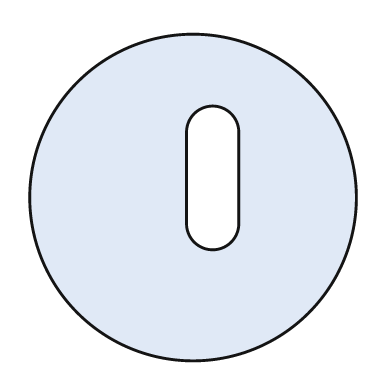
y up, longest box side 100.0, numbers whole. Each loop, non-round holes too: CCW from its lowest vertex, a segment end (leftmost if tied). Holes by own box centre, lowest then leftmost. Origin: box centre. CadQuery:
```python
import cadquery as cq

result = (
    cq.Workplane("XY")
    .moveTo(0.0, 0.0)
    .circle(50.0)
    .moveTo(-2.0, -8.0)
    .threePointArc((6.0, -16.0), (14.0, -8.0))
    .lineTo(14.0, 20.0)
    .threePointArc((6.0, 28.0), (-2.0, 20.0))
    .close()
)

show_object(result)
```